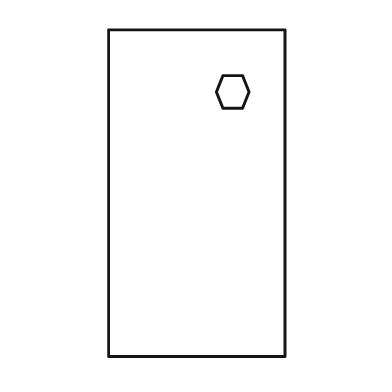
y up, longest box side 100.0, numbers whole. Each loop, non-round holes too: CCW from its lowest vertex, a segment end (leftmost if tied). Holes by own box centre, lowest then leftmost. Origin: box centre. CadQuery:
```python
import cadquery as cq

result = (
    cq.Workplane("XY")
    .moveTo(-27.0, -50.0)
    .lineTo(27.0, -50.0)
    .lineTo(27.0, 50.0)
    .lineTo(-27.0, 50.0)
    .close()
    .moveTo(8.0, 26.0)
    .lineTo(14.0, 26.0)
    .lineTo(16.0, 31.0)
    .lineTo(14.0, 36.0)
    .lineTo(8.0, 36.0)
    .lineTo(6.0, 31.0)
    .close()
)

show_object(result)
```